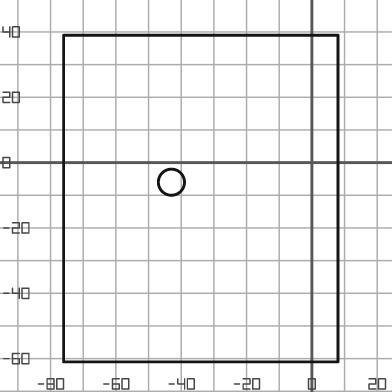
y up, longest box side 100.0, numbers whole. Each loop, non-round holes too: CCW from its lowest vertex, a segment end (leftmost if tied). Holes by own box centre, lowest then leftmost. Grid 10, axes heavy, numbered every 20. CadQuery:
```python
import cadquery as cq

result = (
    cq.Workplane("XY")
    .moveTo(-76.0, -61.0)
    .lineTo(8.0, -61.0)
    .lineTo(8.0, 39.0)
    .lineTo(-76.0, 39.0)
    .close()
    .moveTo(-43.0, -6.0)
    .circle(4.0)
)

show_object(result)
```